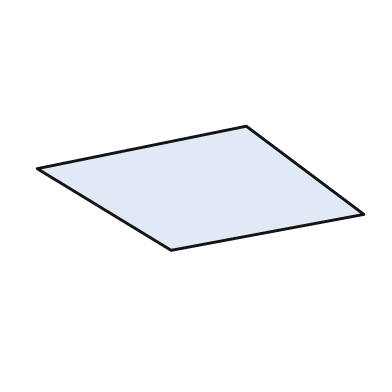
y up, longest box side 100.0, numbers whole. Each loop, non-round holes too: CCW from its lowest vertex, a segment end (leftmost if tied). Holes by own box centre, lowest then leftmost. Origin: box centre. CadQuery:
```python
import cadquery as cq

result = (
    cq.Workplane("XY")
    .moveTo(-9.0, -19.0)
    .lineTo(50.0, -8.0)
    .lineTo(14.0, 19.0)
    .lineTo(-50.0, 6.0)
    .close()
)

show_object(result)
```